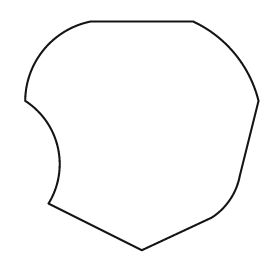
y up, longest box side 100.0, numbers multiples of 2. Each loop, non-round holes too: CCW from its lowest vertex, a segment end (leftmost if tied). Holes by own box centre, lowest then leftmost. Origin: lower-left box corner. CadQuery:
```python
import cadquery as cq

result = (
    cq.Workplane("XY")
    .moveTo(50.0, 0.0)
    .lineTo(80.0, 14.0)
    .threePointArc((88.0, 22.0), (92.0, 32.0))
    .lineTo(100.0, 64.0)
    .threePointArc((90.0, 84.0), (72.0, 98.0))
    .lineTo(28.0, 98.0)
    .threePointArc((8.0, 86.0), (0.0, 64.0))
    .threePointArc((14.0, 44.0), (10.0, 20.0))
    .close()
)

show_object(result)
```